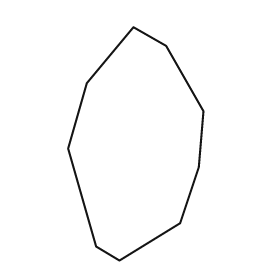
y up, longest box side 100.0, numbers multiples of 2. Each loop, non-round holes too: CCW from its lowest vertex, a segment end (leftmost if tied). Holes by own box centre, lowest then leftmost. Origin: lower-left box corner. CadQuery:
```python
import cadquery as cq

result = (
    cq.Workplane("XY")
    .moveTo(22.0, 0.0)
    .lineTo(48.0, 16.0)
    .lineTo(56.0, 40.0)
    .lineTo(58.0, 64.0)
    .lineTo(42.0, 92.0)
    .lineTo(28.0, 100.0)
    .lineTo(8.0, 76.0)
    .lineTo(0.0, 48.0)
    .lineTo(12.0, 6.0)
    .close()
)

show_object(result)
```